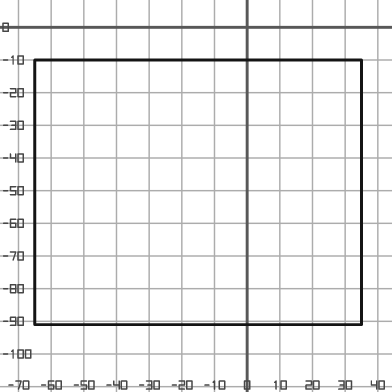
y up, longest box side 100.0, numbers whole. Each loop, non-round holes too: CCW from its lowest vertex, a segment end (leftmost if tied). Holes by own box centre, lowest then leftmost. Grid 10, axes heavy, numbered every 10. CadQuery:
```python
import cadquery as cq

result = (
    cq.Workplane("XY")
    .moveTo(-65.0, -91.0)
    .lineTo(35.0, -91.0)
    .lineTo(35.0, -10.0)
    .lineTo(-65.0, -10.0)
    .close()
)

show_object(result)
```